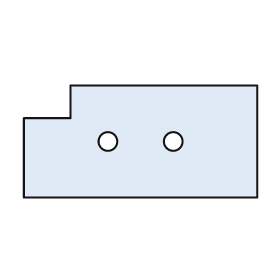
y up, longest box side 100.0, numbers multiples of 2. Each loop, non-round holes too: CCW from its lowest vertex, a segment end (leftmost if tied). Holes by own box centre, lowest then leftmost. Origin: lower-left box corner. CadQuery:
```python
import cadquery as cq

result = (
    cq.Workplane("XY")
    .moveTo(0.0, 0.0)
    .lineTo(100.0, 0.0)
    .lineTo(100.0, 48.0)
    .lineTo(20.0, 48.0)
    .lineTo(20.0, 34.0)
    .lineTo(0.0, 34.0)
    .close()
    .moveTo(36.0, 24.0)
    .circle(4.0)
    .moveTo(64.0, 24.0)
    .circle(4.0)
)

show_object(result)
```